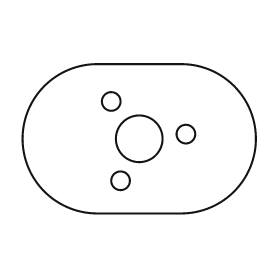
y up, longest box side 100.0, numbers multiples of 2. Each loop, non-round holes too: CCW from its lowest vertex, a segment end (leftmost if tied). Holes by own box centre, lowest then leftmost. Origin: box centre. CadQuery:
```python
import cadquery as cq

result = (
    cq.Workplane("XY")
    .moveTo(-18.0, -32.0)
    .lineTo(18.0, -32.0)
    .threePointArc((50.0, 0.0), (18.0, 32.0))
    .lineTo(-18.0, 32.0)
    .threePointArc((-50.0, 0.0), (-18.0, -32.0))
    .close()
    .moveTo(-8.0, -18.0)
    .circle(4.0)
    .moveTo(0.0, 0.0)
    .circle(10.0)
    .moveTo(20.0, 2.0)
    .circle(4.0)
    .moveTo(-12.0, 16.0)
    .circle(4.0)
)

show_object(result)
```